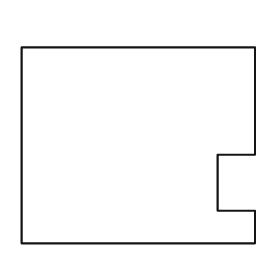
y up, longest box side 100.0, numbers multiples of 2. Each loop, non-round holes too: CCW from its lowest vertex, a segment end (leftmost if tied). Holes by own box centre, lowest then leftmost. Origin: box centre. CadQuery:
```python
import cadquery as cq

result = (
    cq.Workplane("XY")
    .moveTo(-50.0, -42.0)
    .lineTo(50.0, -42.0)
    .lineTo(50.0, -28.0)
    .lineTo(34.0, -28.0)
    .lineTo(34.0, -4.0)
    .lineTo(50.0, -4.0)
    .lineTo(50.0, 42.0)
    .lineTo(-50.0, 42.0)
    .close()
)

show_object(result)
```